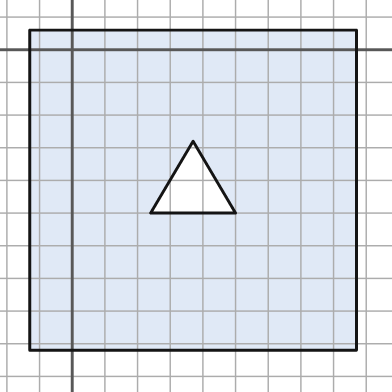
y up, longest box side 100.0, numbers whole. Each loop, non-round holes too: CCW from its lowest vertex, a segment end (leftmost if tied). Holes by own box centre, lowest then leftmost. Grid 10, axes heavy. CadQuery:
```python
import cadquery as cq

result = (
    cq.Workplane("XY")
    .moveTo(-13.0, -92.0)
    .lineTo(87.0, -92.0)
    .lineTo(87.0, 6.0)
    .lineTo(-13.0, 6.0)
    .close()
    .moveTo(24.0, -50.0)
    .lineTo(50.0, -50.0)
    .lineTo(37.0, -28.0)
    .close()
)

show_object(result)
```